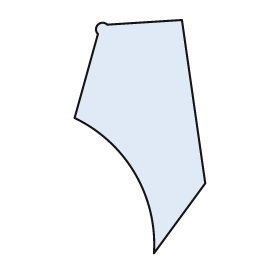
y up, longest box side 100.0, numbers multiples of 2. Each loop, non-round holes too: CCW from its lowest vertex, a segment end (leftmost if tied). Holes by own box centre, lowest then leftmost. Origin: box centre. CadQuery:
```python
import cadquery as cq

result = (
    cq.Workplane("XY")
    .moveTo(6.0, -50.0)
    .lineTo(28.0, -20.0)
    .lineTo(18.0, 50.0)
    .lineTo(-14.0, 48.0)
    .threePointArc((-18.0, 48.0), (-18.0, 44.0))
    .lineTo(-28.0, 8.0)
    .threePointArc((-2.0, -16.0), (6.0, -50.0))
    .close()
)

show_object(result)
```